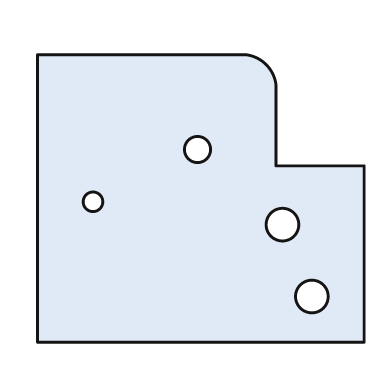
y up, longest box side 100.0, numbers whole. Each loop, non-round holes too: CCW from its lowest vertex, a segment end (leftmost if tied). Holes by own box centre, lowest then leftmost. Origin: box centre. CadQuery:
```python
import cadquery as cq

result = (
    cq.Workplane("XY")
    .moveTo(-50.0, -44.0)
    .lineTo(50.0, -44.0)
    .lineTo(50.0, 10.0)
    .lineTo(23.0, 10.0)
    .lineTo(23.0, 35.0)
    .threePointArc((20.0, 41.0), (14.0, 44.0))
    .lineTo(-50.0, 44.0)
    .close()
    .moveTo(34.0, -30.0)
    .circle(5.0)
    .moveTo(25.0, -8.0)
    .circle(5.0)
    .moveTo(-33.0, -1.0)
    .circle(3.0)
    .moveTo(-1.0, 15.0)
    .circle(4.0)
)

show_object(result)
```